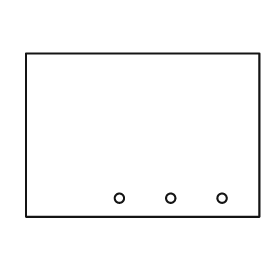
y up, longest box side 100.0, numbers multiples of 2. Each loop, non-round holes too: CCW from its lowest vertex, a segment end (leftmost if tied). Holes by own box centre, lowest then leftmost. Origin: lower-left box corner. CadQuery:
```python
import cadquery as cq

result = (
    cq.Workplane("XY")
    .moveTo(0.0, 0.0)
    .lineTo(100.0, 0.0)
    .lineTo(100.0, 70.0)
    .lineTo(0.0, 70.0)
    .close()
    .moveTo(40.0, 8.0)
    .circle(2.0)
    .moveTo(62.0, 8.0)
    .circle(2.0)
    .moveTo(84.0, 8.0)
    .circle(2.0)
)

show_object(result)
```